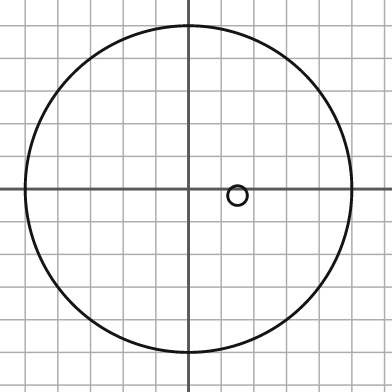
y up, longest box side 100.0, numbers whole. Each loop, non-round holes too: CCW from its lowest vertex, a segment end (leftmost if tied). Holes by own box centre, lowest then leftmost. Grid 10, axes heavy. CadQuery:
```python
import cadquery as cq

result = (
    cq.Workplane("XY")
    .moveTo(0.0, 0.0)
    .circle(50.0)
    .moveTo(15.0, -2.0)
    .circle(3.0)
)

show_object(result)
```